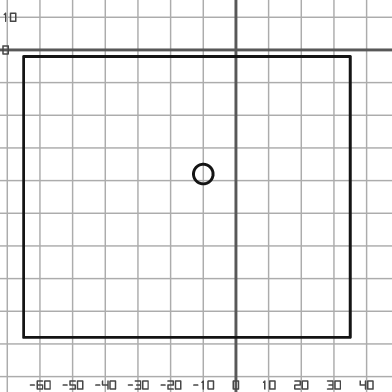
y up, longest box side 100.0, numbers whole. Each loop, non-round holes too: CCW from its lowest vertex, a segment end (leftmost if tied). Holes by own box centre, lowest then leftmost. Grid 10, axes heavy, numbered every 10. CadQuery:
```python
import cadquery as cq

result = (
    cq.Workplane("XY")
    .moveTo(-65.0, -88.0)
    .lineTo(35.0, -88.0)
    .lineTo(35.0, -2.0)
    .lineTo(-65.0, -2.0)
    .close()
    .moveTo(-10.0, -38.0)
    .circle(3.0)
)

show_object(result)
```